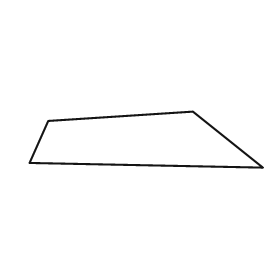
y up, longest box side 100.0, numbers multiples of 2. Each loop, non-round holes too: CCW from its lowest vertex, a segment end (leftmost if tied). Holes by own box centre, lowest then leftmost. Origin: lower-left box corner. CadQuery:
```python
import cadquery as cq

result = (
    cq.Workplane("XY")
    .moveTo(100.0, 0.0)
    .lineTo(70.0, 24.0)
    .lineTo(8.0, 20.0)
    .lineTo(0.0, 2.0)
    .close()
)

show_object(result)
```